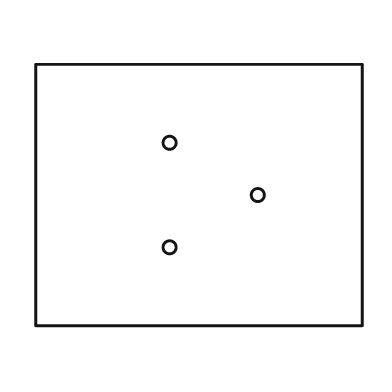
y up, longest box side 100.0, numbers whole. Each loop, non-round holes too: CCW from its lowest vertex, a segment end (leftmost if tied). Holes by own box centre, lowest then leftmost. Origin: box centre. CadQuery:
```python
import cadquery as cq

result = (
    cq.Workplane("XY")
    .moveTo(-50.0, -40.0)
    .lineTo(50.0, -40.0)
    .lineTo(50.0, 40.0)
    .lineTo(-50.0, 40.0)
    .close()
    .moveTo(-9.0, -16.0)
    .circle(2.0)
    .moveTo(18.0, 0.0)
    .circle(2.0)
    .moveTo(-9.0, 16.0)
    .circle(2.0)
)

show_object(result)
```